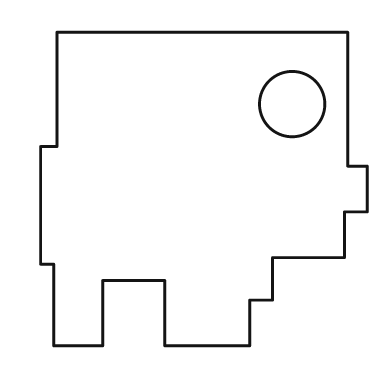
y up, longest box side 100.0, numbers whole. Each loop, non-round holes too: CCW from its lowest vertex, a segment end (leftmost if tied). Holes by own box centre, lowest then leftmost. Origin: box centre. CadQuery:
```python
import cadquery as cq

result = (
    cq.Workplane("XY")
    .moveTo(-46.0, -48.0)
    .lineTo(-31.0, -48.0)
    .lineTo(-31.0, -28.0)
    .lineTo(-12.0, -28.0)
    .lineTo(-12.0, -48.0)
    .lineTo(14.0, -48.0)
    .lineTo(14.0, -34.0)
    .lineTo(21.0, -34.0)
    .lineTo(21.0, -21.0)
    .lineTo(43.0, -21.0)
    .lineTo(43.0, -7.0)
    .lineTo(50.0, -7.0)
    .lineTo(50.0, 7.0)
    .lineTo(44.0, 7.0)
    .lineTo(44.0, 48.0)
    .lineTo(-45.0, 48.0)
    .lineTo(-45.0, 13.0)
    .lineTo(-50.0, 13.0)
    .lineTo(-50.0, -23.0)
    .lineTo(-46.0, -23.0)
    .close()
    .moveTo(27.0, 26.0)
    .circle(10.0)
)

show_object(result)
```